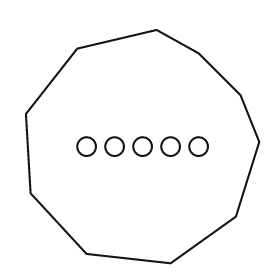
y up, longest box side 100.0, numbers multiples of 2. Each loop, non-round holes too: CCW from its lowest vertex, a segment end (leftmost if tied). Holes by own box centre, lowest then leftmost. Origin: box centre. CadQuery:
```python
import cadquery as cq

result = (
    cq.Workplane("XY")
    .moveTo(12.0, -50.0)
    .lineTo(40.0, -30.0)
    .lineTo(50.0, 2.0)
    .lineTo(42.0, 22.0)
    .lineTo(24.0, 40.0)
    .lineTo(6.0, 50.0)
    .lineTo(-28.0, 42.0)
    .lineTo(-50.0, 14.0)
    .lineTo(-48.0, -20.0)
    .lineTo(-24.0, -46.0)
    .close()
    .moveTo(-24.0, 0.0)
    .circle(4.0)
    .moveTo(-12.0, 0.0)
    .circle(4.0)
    .moveTo(0.0, 0.0)
    .circle(4.0)
    .moveTo(12.0, 0.0)
    .circle(4.0)
    .moveTo(24.0, 0.0)
    .circle(4.0)
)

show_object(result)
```